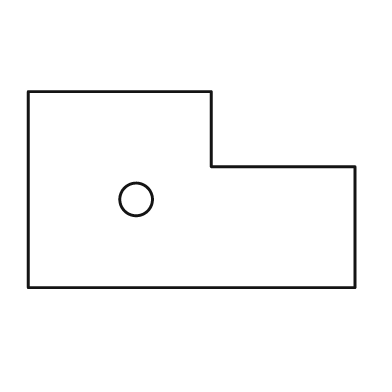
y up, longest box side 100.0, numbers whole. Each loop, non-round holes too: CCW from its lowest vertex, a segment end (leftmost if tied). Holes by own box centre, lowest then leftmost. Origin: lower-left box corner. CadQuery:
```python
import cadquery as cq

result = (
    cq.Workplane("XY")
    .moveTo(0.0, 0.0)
    .lineTo(100.0, 0.0)
    .lineTo(100.0, 37.0)
    .lineTo(56.0, 37.0)
    .lineTo(56.0, 60.0)
    .lineTo(0.0, 60.0)
    .close()
    .moveTo(33.0, 27.0)
    .circle(5.0)
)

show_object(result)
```